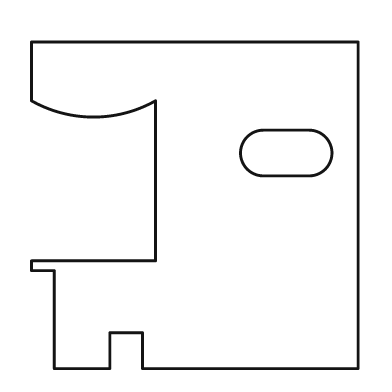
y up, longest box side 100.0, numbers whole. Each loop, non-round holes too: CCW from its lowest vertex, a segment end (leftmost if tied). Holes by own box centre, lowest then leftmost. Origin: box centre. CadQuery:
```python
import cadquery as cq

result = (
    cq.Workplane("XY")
    .moveTo(-43.0, -50.0)
    .lineTo(-26.0, -50.0)
    .lineTo(-26.0, -39.0)
    .lineTo(-16.0, -39.0)
    .lineTo(-16.0, -50.0)
    .lineTo(50.0, -50.0)
    .lineTo(50.0, 50.0)
    .lineTo(-50.0, 50.0)
    .lineTo(-50.0, 32.0)
    .threePointArc((-31.0, 27.0), (-12.0, 32.0))
    .lineTo(-12.0, -17.0)
    .lineTo(-50.0, -17.0)
    .lineTo(-50.0, -20.0)
    .lineTo(-43.0, -20.0)
    .close()
    .moveTo(21.0, 9.0)
    .lineTo(35.0, 9.0)
    .threePointArc((42.0, 16.0), (35.0, 23.0))
    .lineTo(21.0, 23.0)
    .threePointArc((14.0, 16.0), (21.0, 9.0))
    .close()
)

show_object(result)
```